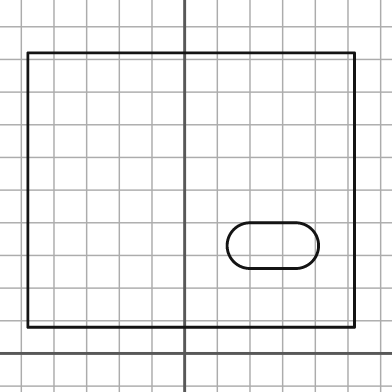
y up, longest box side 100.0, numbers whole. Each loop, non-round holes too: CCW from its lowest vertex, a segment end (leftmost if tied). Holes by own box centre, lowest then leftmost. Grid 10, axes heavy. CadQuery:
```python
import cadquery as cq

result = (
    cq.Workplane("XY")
    .moveTo(-48.0, 8.0)
    .lineTo(52.0, 8.0)
    .lineTo(52.0, 92.0)
    .lineTo(-48.0, 92.0)
    .close()
    .moveTo(20.0, 26.0)
    .lineTo(34.0, 26.0)
    .threePointArc((41.0, 33.0), (34.0, 40.0))
    .lineTo(20.0, 40.0)
    .threePointArc((13.0, 33.0), (20.0, 26.0))
    .close()
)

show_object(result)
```